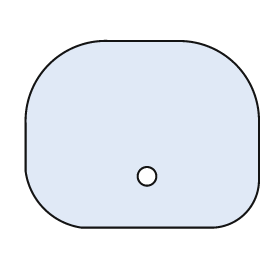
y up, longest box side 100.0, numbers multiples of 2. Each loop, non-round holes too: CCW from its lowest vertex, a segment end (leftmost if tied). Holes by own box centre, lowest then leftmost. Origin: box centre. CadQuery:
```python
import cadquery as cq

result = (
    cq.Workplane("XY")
    .moveTo(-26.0, -40.0)
    .lineTo(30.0, -40.0)
    .threePointArc((44.0, -34.0), (50.0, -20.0))
    .lineTo(50.0, 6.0)
    .threePointArc((40.0, 30.0), (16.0, 40.0))
    .lineTo(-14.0, 40.0)
    .threePointArc((-40.0, 30.0), (-50.0, 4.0))
    .lineTo(-50.0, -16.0)
    .threePointArc((-42.0, -32.0), (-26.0, -40.0))
    .close()
    .moveTo(2.0, -18.0)
    .circle(4.0)
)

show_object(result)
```